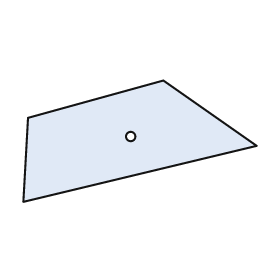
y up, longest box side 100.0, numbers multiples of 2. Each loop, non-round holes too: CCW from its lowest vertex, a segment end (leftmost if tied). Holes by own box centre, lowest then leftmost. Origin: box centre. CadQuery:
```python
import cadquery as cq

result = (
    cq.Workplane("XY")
    .moveTo(-50.0, -26.0)
    .lineTo(50.0, -2.0)
    .lineTo(10.0, 26.0)
    .lineTo(-48.0, 10.0)
    .close()
    .moveTo(-4.0, 2.0)
    .circle(2.0)
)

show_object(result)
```